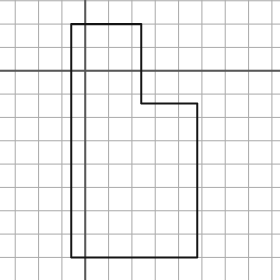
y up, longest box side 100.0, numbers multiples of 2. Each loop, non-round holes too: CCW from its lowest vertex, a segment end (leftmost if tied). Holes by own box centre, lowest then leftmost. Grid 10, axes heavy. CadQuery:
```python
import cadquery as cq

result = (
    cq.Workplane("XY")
    .moveTo(-6.0, -80.0)
    .lineTo(48.0, -80.0)
    .lineTo(48.0, -14.0)
    .lineTo(24.0, -14.0)
    .lineTo(24.0, 20.0)
    .lineTo(-6.0, 20.0)
    .close()
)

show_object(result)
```